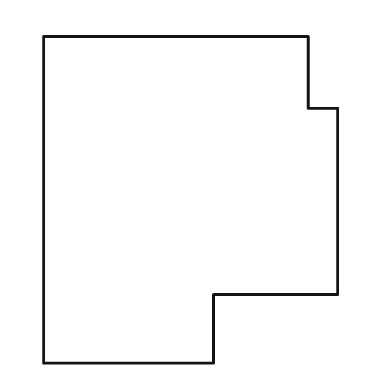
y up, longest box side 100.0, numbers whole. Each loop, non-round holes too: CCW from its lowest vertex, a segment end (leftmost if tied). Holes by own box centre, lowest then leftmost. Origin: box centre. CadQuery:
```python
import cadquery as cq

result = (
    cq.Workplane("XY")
    .moveTo(-45.0, -50.0)
    .lineTo(7.0, -50.0)
    .lineTo(7.0, -29.0)
    .lineTo(45.0, -29.0)
    .lineTo(45.0, 28.0)
    .lineTo(36.0, 28.0)
    .lineTo(36.0, 50.0)
    .lineTo(-45.0, 50.0)
    .close()
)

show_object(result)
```